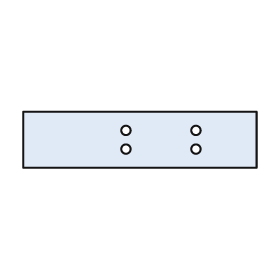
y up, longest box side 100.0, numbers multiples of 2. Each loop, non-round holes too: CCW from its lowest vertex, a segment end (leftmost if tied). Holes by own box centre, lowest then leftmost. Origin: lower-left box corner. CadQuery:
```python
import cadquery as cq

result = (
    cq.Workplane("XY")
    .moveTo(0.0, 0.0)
    .lineTo(100.0, 0.0)
    .lineTo(100.0, 24.0)
    .lineTo(0.0, 24.0)
    .close()
    .moveTo(44.0, 8.0)
    .circle(2.0)
    .moveTo(74.0, 8.0)
    .circle(2.0)
    .moveTo(44.0, 16.0)
    .circle(2.0)
    .moveTo(74.0, 16.0)
    .circle(2.0)
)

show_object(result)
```